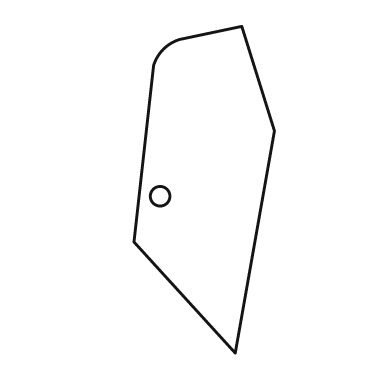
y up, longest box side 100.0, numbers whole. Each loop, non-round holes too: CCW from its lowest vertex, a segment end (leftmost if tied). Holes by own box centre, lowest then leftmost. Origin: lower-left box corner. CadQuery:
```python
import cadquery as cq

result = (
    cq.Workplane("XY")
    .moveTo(31.0, 0.0)
    .lineTo(43.0, 68.0)
    .lineTo(33.0, 100.0)
    .lineTo(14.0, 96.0)
    .threePointArc((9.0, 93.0), (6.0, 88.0))
    .lineTo(0.0, 34.0)
    .close()
    .moveTo(8.0, 48.0)
    .circle(3.0)
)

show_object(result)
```